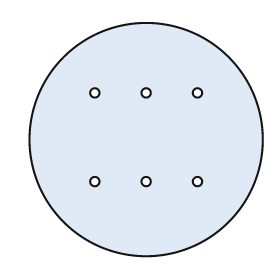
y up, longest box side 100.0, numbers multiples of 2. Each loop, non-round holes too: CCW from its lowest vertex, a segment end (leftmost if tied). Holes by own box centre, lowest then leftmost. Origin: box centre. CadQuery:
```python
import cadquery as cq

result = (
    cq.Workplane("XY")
    .moveTo(0.0, 0.0)
    .circle(50.0)
    .moveTo(-22.0, -18.0)
    .circle(2.0)
    .moveTo(0.0, -18.0)
    .circle(2.0)
    .moveTo(22.0, -18.0)
    .circle(2.0)
    .moveTo(-22.0, 20.0)
    .circle(2.0)
    .moveTo(0.0, 20.0)
    .circle(2.0)
    .moveTo(22.0, 20.0)
    .circle(2.0)
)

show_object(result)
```